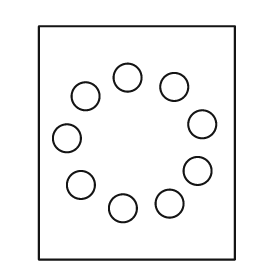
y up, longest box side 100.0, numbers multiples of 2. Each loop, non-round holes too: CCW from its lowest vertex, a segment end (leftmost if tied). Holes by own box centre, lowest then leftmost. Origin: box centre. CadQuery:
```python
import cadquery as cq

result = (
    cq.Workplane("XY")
    .moveTo(-42.0, -50.0)
    .lineTo(42.0, -50.0)
    .lineTo(42.0, 50.0)
    .lineTo(-42.0, 50.0)
    .close()
    .moveTo(-6.0, -28.0)
    .circle(6.0)
    .moveTo(14.0, -26.0)
    .circle(6.0)
    .moveTo(-24.0, -18.0)
    .circle(6.0)
    .moveTo(26.0, -12.0)
    .circle(6.0)
    .moveTo(-30.0, 2.0)
    .circle(6.0)
    .moveTo(28.0, 8.0)
    .circle(6.0)
    .moveTo(-22.0, 20.0)
    .circle(6.0)
    .moveTo(16.0, 24.0)
    .circle(6.0)
    .moveTo(-4.0, 28.0)
    .circle(6.0)
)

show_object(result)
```